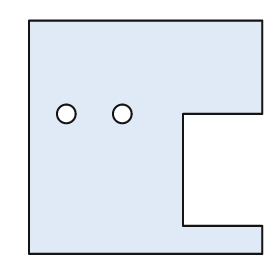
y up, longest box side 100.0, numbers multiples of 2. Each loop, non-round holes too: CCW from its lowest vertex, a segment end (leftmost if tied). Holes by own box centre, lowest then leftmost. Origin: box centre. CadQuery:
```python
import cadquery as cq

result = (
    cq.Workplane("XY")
    .moveTo(-50.0, -50.0)
    .lineTo(50.0, -50.0)
    .lineTo(50.0, -38.0)
    .lineTo(16.0, -38.0)
    .lineTo(16.0, 10.0)
    .lineTo(50.0, 10.0)
    .lineTo(50.0, 50.0)
    .lineTo(-50.0, 50.0)
    .close()
    .moveTo(-34.0, 10.0)
    .circle(4.0)
    .moveTo(-10.0, 10.0)
    .circle(4.0)
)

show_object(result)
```